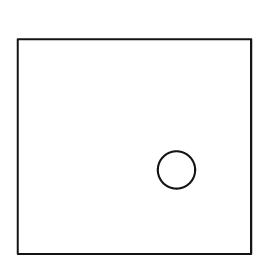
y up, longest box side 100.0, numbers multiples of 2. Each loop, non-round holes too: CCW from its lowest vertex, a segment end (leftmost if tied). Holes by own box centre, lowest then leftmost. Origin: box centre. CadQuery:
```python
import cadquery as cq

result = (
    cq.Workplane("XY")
    .moveTo(-50.0, -46.0)
    .lineTo(50.0, -46.0)
    .lineTo(50.0, 46.0)
    .lineTo(-50.0, 46.0)
    .close()
    .moveTo(18.0, -10.0)
    .circle(8.0)
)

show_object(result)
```